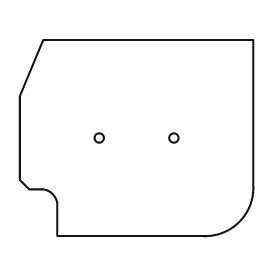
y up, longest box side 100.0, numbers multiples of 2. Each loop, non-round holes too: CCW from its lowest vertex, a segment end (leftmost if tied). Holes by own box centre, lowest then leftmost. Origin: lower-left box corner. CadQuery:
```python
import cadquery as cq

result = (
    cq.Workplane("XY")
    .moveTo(16.0, 0.0)
    .lineTo(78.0, 0.0)
    .threePointArc((94.0, 6.0), (100.0, 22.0))
    .lineTo(100.0, 84.0)
    .lineTo(10.0, 84.0)
    .lineTo(0.0, 60.0)
    .lineTo(0.0, 24.0)
    .lineTo(4.0, 20.0)
    .lineTo(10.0, 20.0)
    .threePointArc((14.0, 18.0), (16.0, 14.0))
    .close()
    .moveTo(34.0, 42.0)
    .circle(2.0)
    .moveTo(66.0, 42.0)
    .circle(2.0)
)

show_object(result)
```